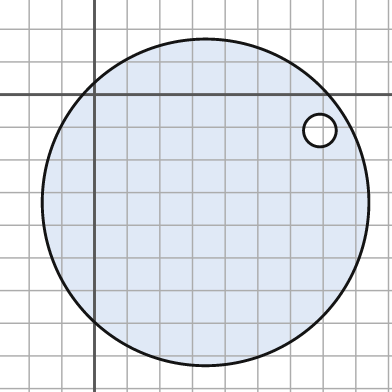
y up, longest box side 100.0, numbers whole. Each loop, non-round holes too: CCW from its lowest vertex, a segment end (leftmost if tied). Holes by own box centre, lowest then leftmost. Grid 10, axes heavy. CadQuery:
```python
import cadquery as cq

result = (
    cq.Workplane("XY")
    .moveTo(34.0, -33.0)
    .circle(50.0)
    .moveTo(69.0, -11.0)
    .circle(5.0)
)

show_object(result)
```